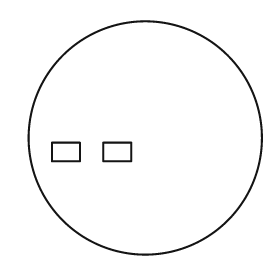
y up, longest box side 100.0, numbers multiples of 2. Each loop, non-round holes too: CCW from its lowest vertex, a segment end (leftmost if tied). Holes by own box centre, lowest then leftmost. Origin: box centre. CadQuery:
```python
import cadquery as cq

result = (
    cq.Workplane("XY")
    .moveTo(0.0, 0.0)
    .circle(50.0)
    .moveTo(-40.0, -10.0)
    .lineTo(-28.0, -10.0)
    .lineTo(-28.0, -2.0)
    .lineTo(-40.0, -2.0)
    .close()
    .moveTo(-18.0, -10.0)
    .lineTo(-6.0, -10.0)
    .lineTo(-6.0, -2.0)
    .lineTo(-18.0, -2.0)
    .close()
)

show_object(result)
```